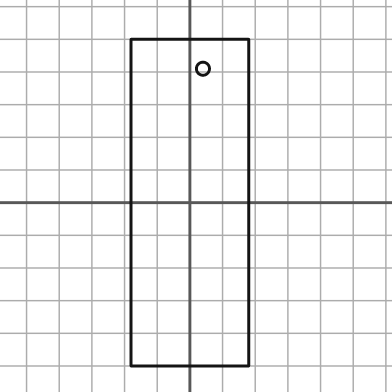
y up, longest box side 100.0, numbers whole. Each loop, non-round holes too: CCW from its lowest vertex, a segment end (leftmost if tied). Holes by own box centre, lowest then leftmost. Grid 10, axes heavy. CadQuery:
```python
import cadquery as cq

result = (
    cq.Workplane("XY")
    .moveTo(-18.0, -50.0)
    .lineTo(18.0, -50.0)
    .lineTo(18.0, 50.0)
    .lineTo(-18.0, 50.0)
    .close()
    .moveTo(4.0, 41.0)
    .circle(2.0)
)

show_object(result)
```